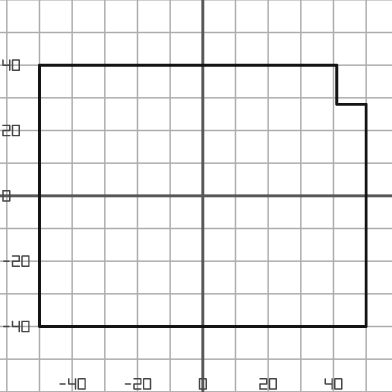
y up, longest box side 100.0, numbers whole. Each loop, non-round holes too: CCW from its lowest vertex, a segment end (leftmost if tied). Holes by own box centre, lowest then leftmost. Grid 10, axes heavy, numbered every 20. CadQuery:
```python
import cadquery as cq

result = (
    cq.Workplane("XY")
    .moveTo(-50.0, -40.0)
    .lineTo(50.0, -40.0)
    .lineTo(50.0, 28.0)
    .lineTo(41.0, 28.0)
    .lineTo(41.0, 40.0)
    .lineTo(-50.0, 40.0)
    .close()
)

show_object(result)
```